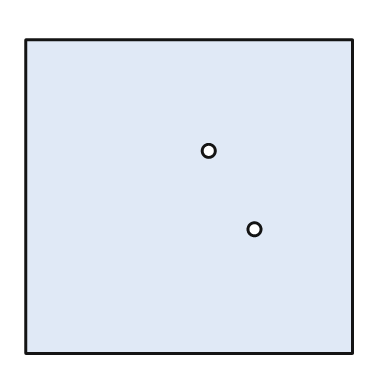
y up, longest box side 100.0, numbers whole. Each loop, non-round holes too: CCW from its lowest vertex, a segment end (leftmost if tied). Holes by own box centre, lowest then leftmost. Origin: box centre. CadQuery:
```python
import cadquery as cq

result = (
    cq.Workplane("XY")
    .moveTo(-50.0, -48.0)
    .lineTo(50.0, -48.0)
    .lineTo(50.0, 48.0)
    .lineTo(-50.0, 48.0)
    .close()
    .moveTo(20.0, -10.0)
    .circle(2.0)
    .moveTo(6.0, 14.0)
    .circle(2.0)
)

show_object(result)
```